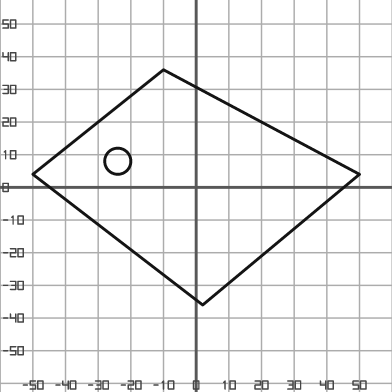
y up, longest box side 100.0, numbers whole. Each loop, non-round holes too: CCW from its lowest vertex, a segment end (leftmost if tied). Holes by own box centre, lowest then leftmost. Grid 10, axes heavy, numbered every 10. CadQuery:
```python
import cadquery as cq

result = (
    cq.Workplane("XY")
    .moveTo(2.0, -36.0)
    .lineTo(50.0, 4.0)
    .lineTo(-10.0, 36.0)
    .lineTo(-50.0, 4.0)
    .close()
    .moveTo(-24.0, 8.0)
    .circle(4.0)
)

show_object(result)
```